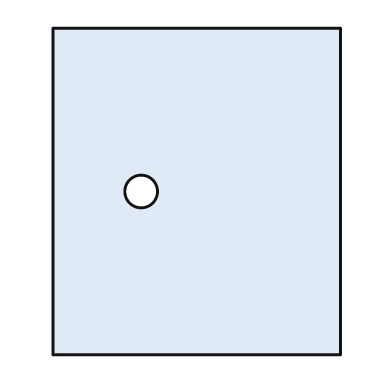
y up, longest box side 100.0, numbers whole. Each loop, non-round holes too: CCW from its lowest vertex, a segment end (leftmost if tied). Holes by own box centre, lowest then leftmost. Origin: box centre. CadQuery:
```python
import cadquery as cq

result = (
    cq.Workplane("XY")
    .moveTo(-44.0, -50.0)
    .lineTo(44.0, -50.0)
    .lineTo(44.0, 50.0)
    .lineTo(-44.0, 50.0)
    .close()
    .moveTo(-17.0, 0.0)
    .circle(5.0)
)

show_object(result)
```